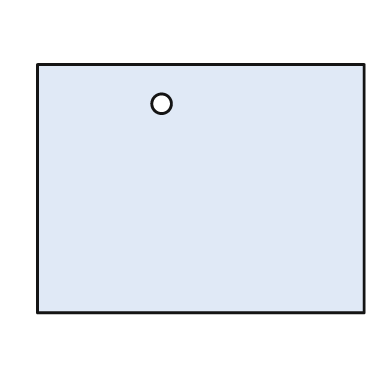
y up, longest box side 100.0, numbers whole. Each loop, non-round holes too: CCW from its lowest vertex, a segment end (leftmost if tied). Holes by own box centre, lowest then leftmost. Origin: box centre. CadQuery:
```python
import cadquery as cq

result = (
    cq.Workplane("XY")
    .moveTo(-50.0, -38.0)
    .lineTo(50.0, -38.0)
    .lineTo(50.0, 38.0)
    .lineTo(-50.0, 38.0)
    .close()
    .moveTo(-12.0, 26.0)
    .circle(3.0)
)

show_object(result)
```